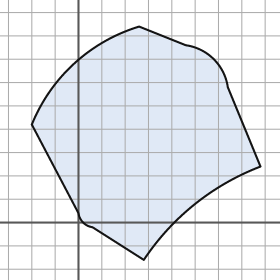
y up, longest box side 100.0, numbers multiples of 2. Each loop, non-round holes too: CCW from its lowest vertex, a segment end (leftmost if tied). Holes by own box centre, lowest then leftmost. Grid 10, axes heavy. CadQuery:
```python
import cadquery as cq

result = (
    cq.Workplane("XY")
    .moveTo(28.0, -16.0)
    .threePointArc((50.0, 8.0), (78.0, 24.0))
    .lineTo(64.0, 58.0)
    .threePointArc((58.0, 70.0), (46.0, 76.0))
    .lineTo(26.0, 84.0)
    .threePointArc((-2.0, 68.0), (-20.0, 42.0))
    .lineTo(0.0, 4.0)
    .threePointArc((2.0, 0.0), (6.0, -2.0))
    .close()
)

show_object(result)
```